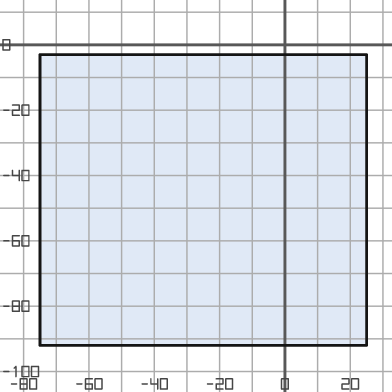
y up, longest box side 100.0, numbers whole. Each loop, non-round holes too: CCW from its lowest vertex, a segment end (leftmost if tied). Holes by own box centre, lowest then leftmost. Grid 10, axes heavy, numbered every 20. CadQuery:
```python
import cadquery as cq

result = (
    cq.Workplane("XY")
    .moveTo(-75.0, -92.0)
    .lineTo(25.0, -92.0)
    .lineTo(25.0, -3.0)
    .lineTo(-75.0, -3.0)
    .close()
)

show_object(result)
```